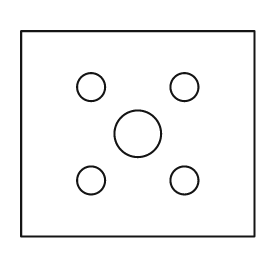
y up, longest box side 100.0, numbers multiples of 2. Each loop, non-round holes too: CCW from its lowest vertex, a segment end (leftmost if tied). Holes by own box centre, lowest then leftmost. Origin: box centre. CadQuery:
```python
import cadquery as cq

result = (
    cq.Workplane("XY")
    .moveTo(-50.0, -44.0)
    .lineTo(50.0, -44.0)
    .lineTo(50.0, 44.0)
    .lineTo(-50.0, 44.0)
    .close()
    .moveTo(-20.0, -20.0)
    .circle(6.0)
    .moveTo(20.0, -20.0)
    .circle(6.0)
    .moveTo(0.0, 0.0)
    .circle(10.0)
    .moveTo(-20.0, 20.0)
    .circle(6.0)
    .moveTo(20.0, 20.0)
    .circle(6.0)
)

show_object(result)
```